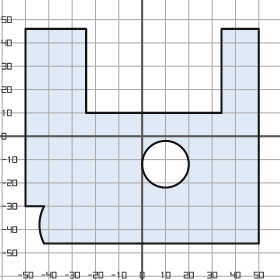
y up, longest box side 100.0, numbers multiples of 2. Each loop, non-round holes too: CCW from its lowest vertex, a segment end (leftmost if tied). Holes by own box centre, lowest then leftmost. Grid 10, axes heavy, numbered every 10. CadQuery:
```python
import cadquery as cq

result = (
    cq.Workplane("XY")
    .moveTo(-42.0, -46.0)
    .lineTo(50.0, -46.0)
    .lineTo(50.0, 46.0)
    .lineTo(34.0, 46.0)
    .lineTo(34.0, 10.0)
    .lineTo(-24.0, 10.0)
    .lineTo(-24.0, 46.0)
    .lineTo(-50.0, 46.0)
    .lineTo(-50.0, -30.0)
    .lineTo(-42.0, -30.0)
    .threePointArc((-44.0, -38.0), (-42.0, -46.0))
    .close()
    .moveTo(10.0, -12.0)
    .circle(10.0)
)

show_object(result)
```